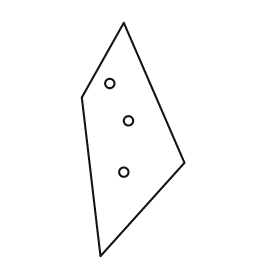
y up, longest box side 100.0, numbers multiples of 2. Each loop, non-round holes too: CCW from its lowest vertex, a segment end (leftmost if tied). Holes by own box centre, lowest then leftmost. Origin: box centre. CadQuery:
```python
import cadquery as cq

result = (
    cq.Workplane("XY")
    .moveTo(-14.0, -50.0)
    .lineTo(22.0, -10.0)
    .lineTo(-4.0, 50.0)
    .lineTo(-22.0, 18.0)
    .close()
    .moveTo(-4.0, -14.0)
    .circle(2.0)
    .moveTo(-2.0, 8.0)
    .circle(2.0)
    .moveTo(-10.0, 24.0)
    .circle(2.0)
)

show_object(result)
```